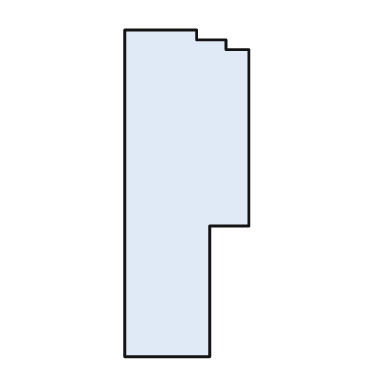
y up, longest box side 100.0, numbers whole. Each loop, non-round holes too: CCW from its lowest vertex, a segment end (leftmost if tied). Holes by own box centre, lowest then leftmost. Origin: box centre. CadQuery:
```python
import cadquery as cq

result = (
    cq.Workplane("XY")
    .moveTo(-19.0, -50.0)
    .lineTo(7.0, -50.0)
    .lineTo(7.0, -10.0)
    .lineTo(19.0, -10.0)
    .lineTo(19.0, 44.0)
    .lineTo(12.0, 44.0)
    .lineTo(12.0, 47.0)
    .lineTo(3.0, 47.0)
    .lineTo(3.0, 50.0)
    .lineTo(-19.0, 50.0)
    .close()
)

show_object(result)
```